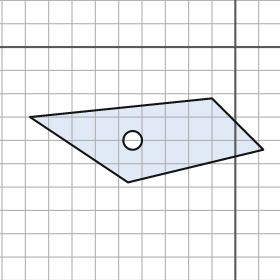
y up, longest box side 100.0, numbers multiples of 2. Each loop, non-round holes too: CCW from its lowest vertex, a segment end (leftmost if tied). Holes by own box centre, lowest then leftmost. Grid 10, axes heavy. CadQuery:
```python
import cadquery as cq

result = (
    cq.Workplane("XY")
    .moveTo(-46.0, -58.0)
    .lineTo(12.0, -44.0)
    .lineTo(-10.0, -22.0)
    .lineTo(-88.0, -30.0)
    .close()
    .moveTo(-44.0, -40.0)
    .circle(4.0)
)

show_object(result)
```